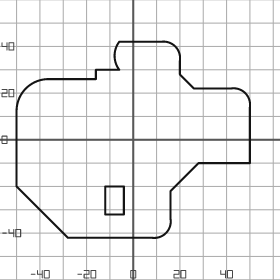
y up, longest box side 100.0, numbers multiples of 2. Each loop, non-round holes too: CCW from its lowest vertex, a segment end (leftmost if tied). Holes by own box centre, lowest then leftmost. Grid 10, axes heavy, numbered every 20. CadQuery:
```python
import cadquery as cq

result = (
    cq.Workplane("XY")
    .moveTo(-28.0, -42.0)
    .lineTo(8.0, -42.0)
    .threePointArc((14.0, -40.0), (16.0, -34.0))
    .lineTo(16.0, -22.0)
    .lineTo(28.0, -10.0)
    .lineTo(50.0, -10.0)
    .lineTo(50.0, 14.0)
    .threePointArc((48.0, 20.0), (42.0, 22.0))
    .lineTo(26.0, 22.0)
    .lineTo(20.0, 28.0)
    .lineTo(20.0, 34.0)
    .threePointArc((18.0, 40.0), (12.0, 42.0))
    .lineTo(-6.0, 42.0)
    .threePointArc((-8.0, 36.0), (-6.0, 30.0))
    .lineTo(-16.0, 30.0)
    .lineTo(-16.0, 26.0)
    .lineTo(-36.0, 26.0)
    .threePointArc((-46.0, 22.0), (-50.0, 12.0))
    .lineTo(-50.0, -20.0)
    .close()
    .moveTo(-12.0, -32.0)
    .lineTo(-4.0, -32.0)
    .lineTo(-4.0, -20.0)
    .lineTo(-12.0, -20.0)
    .close()
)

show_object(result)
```